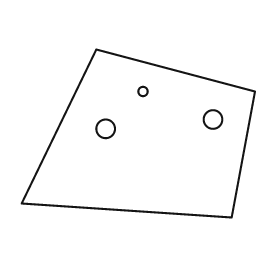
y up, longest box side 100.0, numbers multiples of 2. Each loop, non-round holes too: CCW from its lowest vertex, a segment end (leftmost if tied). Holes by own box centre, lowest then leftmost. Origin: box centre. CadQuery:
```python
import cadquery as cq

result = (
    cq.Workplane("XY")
    .moveTo(40.0, -36.0)
    .lineTo(50.0, 18.0)
    .lineTo(-18.0, 36.0)
    .lineTo(-50.0, -30.0)
    .close()
    .moveTo(-14.0, 2.0)
    .circle(4.0)
    .moveTo(32.0, 6.0)
    .circle(4.0)
    .moveTo(2.0, 18.0)
    .circle(2.0)
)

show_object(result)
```